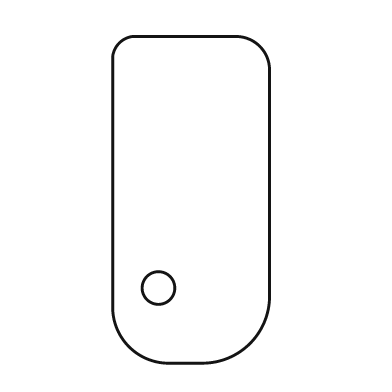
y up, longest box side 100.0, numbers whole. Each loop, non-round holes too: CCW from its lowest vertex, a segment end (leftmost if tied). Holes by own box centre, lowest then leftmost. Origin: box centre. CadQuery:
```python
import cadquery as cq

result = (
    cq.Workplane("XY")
    .moveTo(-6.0, -50.0)
    .lineTo(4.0, -50.0)
    .threePointArc((18.0, -44.0), (24.0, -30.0))
    .lineTo(24.0, 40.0)
    .threePointArc((21.0, 47.0), (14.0, 50.0))
    .lineTo(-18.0, 50.0)
    .threePointArc((-22.0, 48.0), (-24.0, 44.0))
    .lineTo(-24.0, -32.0)
    .threePointArc((-19.0, -45.0), (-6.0, -50.0))
    .close()
    .moveTo(-10.0, -27.0)
    .circle(5.0)
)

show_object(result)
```